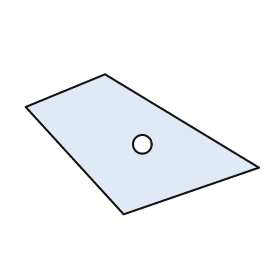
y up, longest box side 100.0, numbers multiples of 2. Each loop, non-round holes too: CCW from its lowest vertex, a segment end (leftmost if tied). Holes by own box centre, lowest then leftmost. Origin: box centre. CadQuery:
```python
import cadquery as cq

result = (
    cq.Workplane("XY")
    .moveTo(-8.0, -30.0)
    .lineTo(50.0, -10.0)
    .lineTo(-16.0, 30.0)
    .lineTo(-50.0, 16.0)
    .close()
    .moveTo(0.0, 0.0)
    .circle(4.0)
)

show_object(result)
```